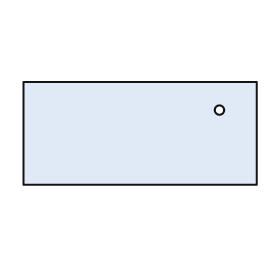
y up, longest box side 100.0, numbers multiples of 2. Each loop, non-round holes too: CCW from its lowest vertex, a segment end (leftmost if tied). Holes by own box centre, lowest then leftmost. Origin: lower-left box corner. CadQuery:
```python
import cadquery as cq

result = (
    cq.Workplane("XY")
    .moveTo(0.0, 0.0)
    .lineTo(100.0, 0.0)
    .lineTo(100.0, 44.0)
    .lineTo(0.0, 44.0)
    .close()
    .moveTo(84.0, 32.0)
    .circle(2.0)
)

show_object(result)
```